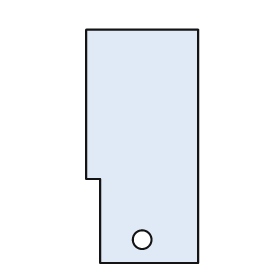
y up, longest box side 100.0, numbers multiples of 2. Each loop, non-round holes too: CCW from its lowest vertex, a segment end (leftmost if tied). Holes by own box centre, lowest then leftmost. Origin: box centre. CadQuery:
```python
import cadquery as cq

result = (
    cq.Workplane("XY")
    .moveTo(-18.0, -50.0)
    .lineTo(24.0, -50.0)
    .lineTo(24.0, 50.0)
    .lineTo(-24.0, 50.0)
    .lineTo(-24.0, -14.0)
    .lineTo(-18.0, -14.0)
    .close()
    .moveTo(0.0, -40.0)
    .circle(4.0)
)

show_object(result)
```